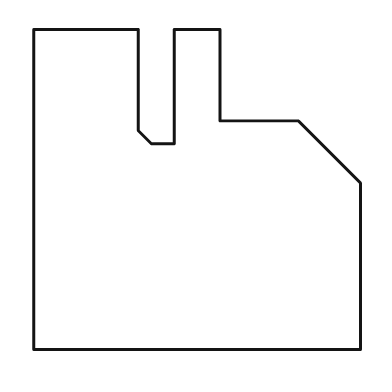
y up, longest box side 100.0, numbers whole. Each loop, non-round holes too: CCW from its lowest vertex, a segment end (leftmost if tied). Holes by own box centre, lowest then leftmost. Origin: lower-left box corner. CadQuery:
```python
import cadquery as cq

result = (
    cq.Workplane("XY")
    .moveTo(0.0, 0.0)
    .lineTo(100.0, 0.0)
    .lineTo(100.0, 51.0)
    .lineTo(81.0, 70.0)
    .lineTo(57.0, 70.0)
    .lineTo(57.0, 98.0)
    .lineTo(43.0, 98.0)
    .lineTo(43.0, 63.0)
    .lineTo(36.0, 63.0)
    .lineTo(32.0, 67.0)
    .lineTo(32.0, 98.0)
    .lineTo(0.0, 98.0)
    .close()
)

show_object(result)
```